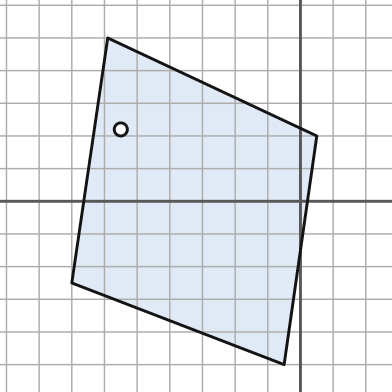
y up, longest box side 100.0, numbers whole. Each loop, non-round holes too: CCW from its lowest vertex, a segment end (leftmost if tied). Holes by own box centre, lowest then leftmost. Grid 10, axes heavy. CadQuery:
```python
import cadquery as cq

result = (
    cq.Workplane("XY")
    .moveTo(-5.0, -50.0)
    .lineTo(5.0, 20.0)
    .lineTo(-59.0, 50.0)
    .lineTo(-70.0, -25.0)
    .close()
    .moveTo(-55.0, 22.0)
    .circle(2.0)
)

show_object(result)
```